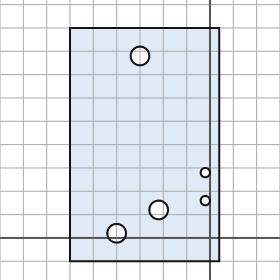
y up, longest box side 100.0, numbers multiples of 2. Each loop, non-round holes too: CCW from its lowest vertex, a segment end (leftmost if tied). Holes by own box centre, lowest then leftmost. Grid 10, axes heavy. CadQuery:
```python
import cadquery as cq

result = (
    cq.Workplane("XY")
    .moveTo(-60.0, -10.0)
    .lineTo(4.0, -10.0)
    .lineTo(4.0, 90.0)
    .lineTo(-60.0, 90.0)
    .close()
    .moveTo(-40.0, 2.0)
    .circle(4.0)
    .moveTo(-22.0, 12.0)
    .circle(4.0)
    .moveTo(-2.0, 16.0)
    .circle(2.0)
    .moveTo(-2.0, 28.0)
    .circle(2.0)
    .moveTo(-30.0, 78.0)
    .circle(4.0)
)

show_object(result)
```